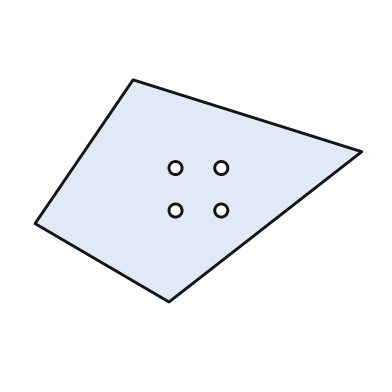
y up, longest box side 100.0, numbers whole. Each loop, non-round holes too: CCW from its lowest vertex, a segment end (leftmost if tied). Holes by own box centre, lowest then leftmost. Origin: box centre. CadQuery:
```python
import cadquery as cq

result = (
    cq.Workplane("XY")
    .moveTo(-9.0, -34.0)
    .lineTo(50.0, 12.0)
    .lineTo(-20.0, 34.0)
    .lineTo(-50.0, -10.0)
    .close()
    .moveTo(-7.0, -6.0)
    .circle(2.0)
    .moveTo(7.0, -6.0)
    .circle(2.0)
    .moveTo(-7.0, 7.0)
    .circle(2.0)
    .moveTo(7.0, 7.0)
    .circle(2.0)
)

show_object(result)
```